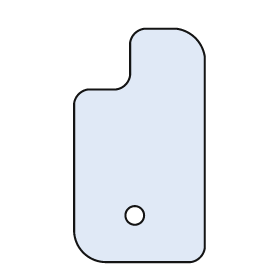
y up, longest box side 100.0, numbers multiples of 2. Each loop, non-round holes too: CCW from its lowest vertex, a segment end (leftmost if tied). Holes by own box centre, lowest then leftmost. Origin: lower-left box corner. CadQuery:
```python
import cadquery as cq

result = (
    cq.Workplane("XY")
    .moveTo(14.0, 0.0)
    .lineTo(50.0, 0.0)
    .threePointArc((54.0, 2.0), (56.0, 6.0))
    .lineTo(56.0, 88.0)
    .threePointArc((52.0, 96.0), (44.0, 100.0))
    .lineTo(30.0, 100.0)
    .threePointArc((26.0, 98.0), (24.0, 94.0))
    .lineTo(24.0, 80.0)
    .threePointArc((22.0, 76.0), (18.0, 74.0))
    .lineTo(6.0, 74.0)
    .threePointArc((2.0, 72.0), (0.0, 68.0))
    .lineTo(0.0, 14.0)
    .threePointArc((4.0, 4.0), (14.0, 0.0))
    .close()
    .moveTo(26.0, 20.0)
    .circle(4.0)
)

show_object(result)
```